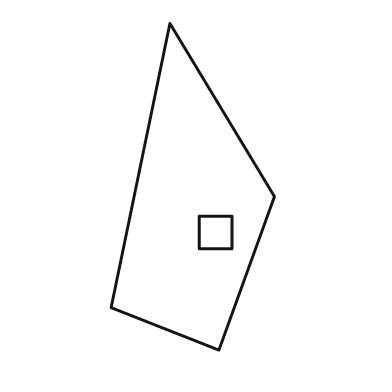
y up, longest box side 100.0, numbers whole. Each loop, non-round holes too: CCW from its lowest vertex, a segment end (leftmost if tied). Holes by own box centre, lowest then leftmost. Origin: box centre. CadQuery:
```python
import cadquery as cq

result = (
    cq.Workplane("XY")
    .moveTo(8.0, -50.0)
    .lineTo(25.0, -3.0)
    .lineTo(-7.0, 50.0)
    .lineTo(-25.0, -37.0)
    .close()
    .moveTo(2.0, -19.0)
    .lineTo(12.0, -19.0)
    .lineTo(12.0, -9.0)
    .lineTo(2.0, -9.0)
    .close()
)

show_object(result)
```